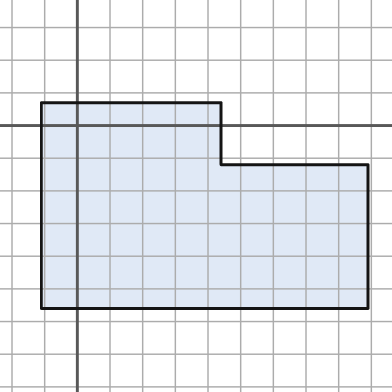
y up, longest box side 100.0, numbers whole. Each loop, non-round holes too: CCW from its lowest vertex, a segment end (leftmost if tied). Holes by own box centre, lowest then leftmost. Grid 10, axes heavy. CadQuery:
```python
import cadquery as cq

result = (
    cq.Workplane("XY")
    .moveTo(-11.0, -56.0)
    .lineTo(89.0, -56.0)
    .lineTo(89.0, -12.0)
    .lineTo(44.0, -12.0)
    .lineTo(44.0, 7.0)
    .lineTo(-11.0, 7.0)
    .close()
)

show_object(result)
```